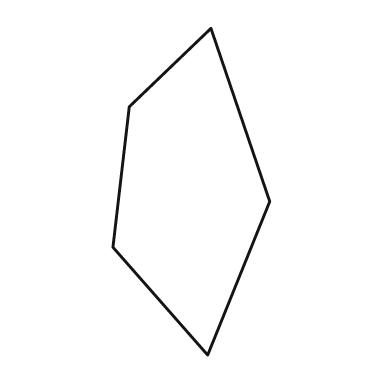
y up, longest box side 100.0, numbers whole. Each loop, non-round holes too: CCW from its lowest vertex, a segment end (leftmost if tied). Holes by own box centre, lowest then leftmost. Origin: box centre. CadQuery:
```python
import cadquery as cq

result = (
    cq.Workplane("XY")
    .moveTo(5.0, -50.0)
    .lineTo(24.0, -3.0)
    .lineTo(6.0, 50.0)
    .lineTo(-19.0, 26.0)
    .lineTo(-24.0, -17.0)
    .close()
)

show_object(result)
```